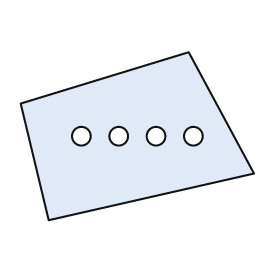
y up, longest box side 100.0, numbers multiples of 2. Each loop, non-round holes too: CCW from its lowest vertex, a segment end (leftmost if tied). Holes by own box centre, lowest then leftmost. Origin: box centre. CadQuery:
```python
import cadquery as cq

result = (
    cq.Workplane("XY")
    .moveTo(-38.0, -36.0)
    .lineTo(50.0, -16.0)
    .lineTo(22.0, 36.0)
    .lineTo(-50.0, 14.0)
    .close()
    .moveTo(-24.0, 0.0)
    .circle(4.0)
    .moveTo(-8.0, 0.0)
    .circle(4.0)
    .moveTo(8.0, 0.0)
    .circle(4.0)
    .moveTo(24.0, 0.0)
    .circle(4.0)
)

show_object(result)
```